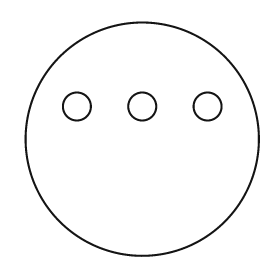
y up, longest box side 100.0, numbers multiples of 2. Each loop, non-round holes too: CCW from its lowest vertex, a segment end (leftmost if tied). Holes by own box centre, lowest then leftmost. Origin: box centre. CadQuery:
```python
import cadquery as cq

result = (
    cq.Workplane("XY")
    .moveTo(0.0, 0.0)
    .circle(50.0)
    .moveTo(-28.0, 14.0)
    .circle(6.0)
    .moveTo(0.0, 14.0)
    .circle(6.0)
    .moveTo(28.0, 14.0)
    .circle(6.0)
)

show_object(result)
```